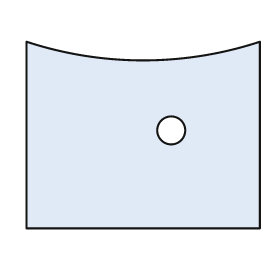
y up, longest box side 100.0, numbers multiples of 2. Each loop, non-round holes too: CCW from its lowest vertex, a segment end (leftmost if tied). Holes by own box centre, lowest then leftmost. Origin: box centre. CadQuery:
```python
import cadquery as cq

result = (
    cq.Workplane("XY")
    .moveTo(-50.0, -40.0)
    .lineTo(50.0, -40.0)
    .lineTo(50.0, 40.0)
    .threePointArc((0.0, 32.0), (-50.0, 40.0))
    .close()
    .moveTo(12.0, 2.0)
    .circle(6.0)
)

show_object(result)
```